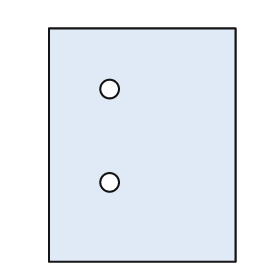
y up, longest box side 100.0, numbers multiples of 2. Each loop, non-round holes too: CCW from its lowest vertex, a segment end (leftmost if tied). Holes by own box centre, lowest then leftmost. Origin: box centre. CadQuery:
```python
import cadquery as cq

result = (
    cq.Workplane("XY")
    .moveTo(-40.0, -50.0)
    .lineTo(40.0, -50.0)
    .lineTo(40.0, 50.0)
    .lineTo(-40.0, 50.0)
    .close()
    .moveTo(-14.0, -16.0)
    .circle(4.0)
    .moveTo(-14.0, 24.0)
    .circle(4.0)
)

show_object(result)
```